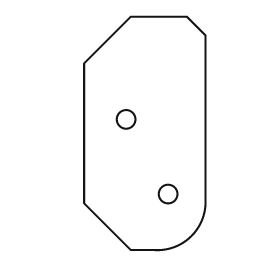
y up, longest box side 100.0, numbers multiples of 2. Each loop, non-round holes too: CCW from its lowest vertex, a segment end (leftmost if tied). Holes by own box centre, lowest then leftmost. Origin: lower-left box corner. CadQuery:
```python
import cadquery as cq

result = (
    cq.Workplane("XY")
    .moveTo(20.0, 0.0)
    .lineTo(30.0, 0.0)
    .threePointArc((46.0, 6.0), (52.0, 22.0))
    .lineTo(52.0, 92.0)
    .lineTo(44.0, 100.0)
    .lineTo(20.0, 100.0)
    .lineTo(0.0, 80.0)
    .lineTo(0.0, 20.0)
    .close()
    .moveTo(36.0, 24.0)
    .circle(4.0)
    .moveTo(18.0, 56.0)
    .circle(4.0)
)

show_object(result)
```